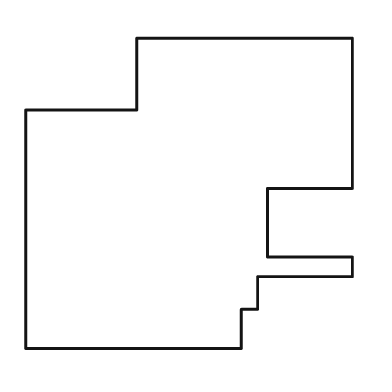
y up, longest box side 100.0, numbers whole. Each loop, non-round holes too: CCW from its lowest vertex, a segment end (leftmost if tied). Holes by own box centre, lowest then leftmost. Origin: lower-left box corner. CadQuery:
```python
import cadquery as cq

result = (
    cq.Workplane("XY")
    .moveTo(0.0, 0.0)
    .lineTo(66.0, 0.0)
    .lineTo(66.0, 12.0)
    .lineTo(71.0, 12.0)
    .lineTo(71.0, 22.0)
    .lineTo(100.0, 22.0)
    .lineTo(100.0, 28.0)
    .lineTo(74.0, 28.0)
    .lineTo(74.0, 49.0)
    .lineTo(100.0, 49.0)
    .lineTo(100.0, 95.0)
    .lineTo(34.0, 95.0)
    .lineTo(34.0, 73.0)
    .lineTo(0.0, 73.0)
    .close()
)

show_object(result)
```